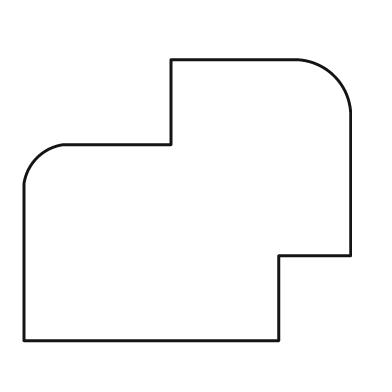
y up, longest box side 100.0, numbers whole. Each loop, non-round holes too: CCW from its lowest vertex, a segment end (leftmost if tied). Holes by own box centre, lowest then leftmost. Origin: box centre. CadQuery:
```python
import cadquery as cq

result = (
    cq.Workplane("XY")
    .moveTo(-50.0, -43.0)
    .lineTo(28.0, -43.0)
    .lineTo(28.0, -17.0)
    .lineTo(50.0, -17.0)
    .lineTo(50.0, 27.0)
    .threePointArc((45.0, 38.0), (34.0, 43.0))
    .lineTo(-5.0, 43.0)
    .lineTo(-5.0, 17.0)
    .lineTo(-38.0, 17.0)
    .threePointArc((-46.0, 13.0), (-50.0, 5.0))
    .close()
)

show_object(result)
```